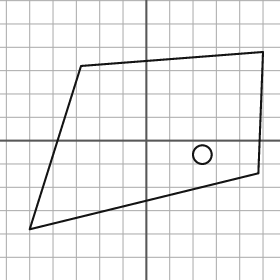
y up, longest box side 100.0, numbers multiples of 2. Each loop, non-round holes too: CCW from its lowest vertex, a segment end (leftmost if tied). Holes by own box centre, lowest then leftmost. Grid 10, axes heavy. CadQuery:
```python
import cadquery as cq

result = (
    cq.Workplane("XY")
    .moveTo(-50.0, -38.0)
    .lineTo(48.0, -14.0)
    .lineTo(50.0, 38.0)
    .lineTo(-28.0, 32.0)
    .close()
    .moveTo(24.0, -6.0)
    .circle(4.0)
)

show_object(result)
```